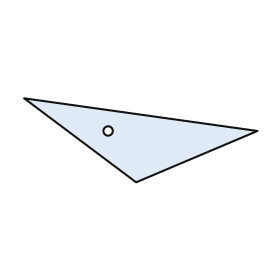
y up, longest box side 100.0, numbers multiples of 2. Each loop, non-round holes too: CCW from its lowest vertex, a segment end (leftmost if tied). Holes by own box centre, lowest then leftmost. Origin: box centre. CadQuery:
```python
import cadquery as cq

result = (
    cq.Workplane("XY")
    .moveTo(-2.0, -18.0)
    .lineTo(50.0, 4.0)
    .lineTo(-50.0, 18.0)
    .close()
    .moveTo(-14.0, 4.0)
    .circle(2.0)
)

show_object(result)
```